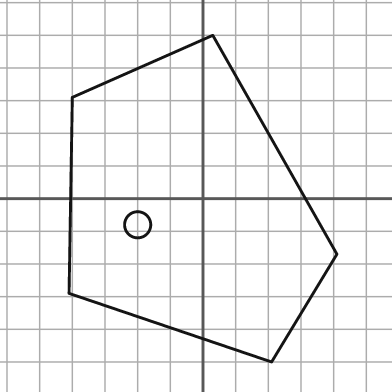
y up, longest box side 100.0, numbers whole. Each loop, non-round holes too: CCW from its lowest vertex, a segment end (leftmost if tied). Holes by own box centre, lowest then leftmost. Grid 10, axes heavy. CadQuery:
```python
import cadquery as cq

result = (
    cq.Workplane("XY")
    .moveTo(21.0, -50.0)
    .lineTo(41.0, -17.0)
    .lineTo(3.0, 50.0)
    .lineTo(-40.0, 31.0)
    .lineTo(-41.0, -29.0)
    .close()
    .moveTo(-20.0, -8.0)
    .circle(4.0)
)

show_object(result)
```